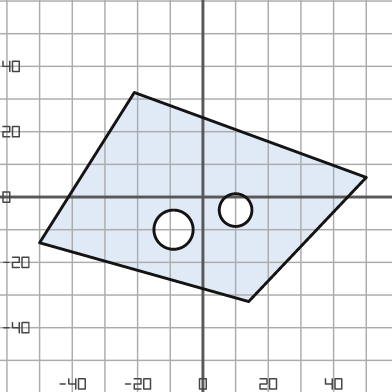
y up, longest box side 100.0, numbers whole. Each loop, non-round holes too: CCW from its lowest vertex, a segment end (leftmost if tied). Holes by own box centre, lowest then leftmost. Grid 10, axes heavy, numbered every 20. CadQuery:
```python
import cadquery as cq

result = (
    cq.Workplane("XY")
    .moveTo(14.0, -32.0)
    .lineTo(50.0, 6.0)
    .lineTo(-21.0, 32.0)
    .lineTo(-50.0, -14.0)
    .close()
    .moveTo(-9.0, -10.0)
    .circle(6.0)
    .moveTo(10.0, -4.0)
    .circle(5.0)
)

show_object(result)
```